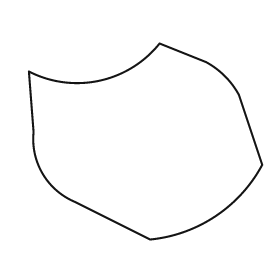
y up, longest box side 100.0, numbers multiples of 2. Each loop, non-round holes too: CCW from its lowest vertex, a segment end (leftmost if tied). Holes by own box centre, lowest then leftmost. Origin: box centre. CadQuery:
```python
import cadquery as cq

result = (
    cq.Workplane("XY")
    .moveTo(2.0, -42.0)
    .threePointArc((30.0, -32.0), (50.0, -10.0))
    .lineTo(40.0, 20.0)
    .threePointArc((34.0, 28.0), (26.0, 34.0))
    .lineTo(6.0, 42.0)
    .threePointArc((-20.0, 26.0), (-50.0, 30.0))
    .lineTo(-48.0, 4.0)
    .threePointArc((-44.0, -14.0), (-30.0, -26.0))
    .close()
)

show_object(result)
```